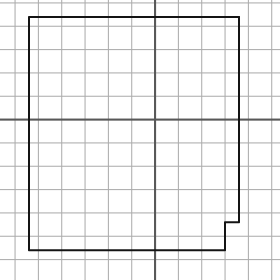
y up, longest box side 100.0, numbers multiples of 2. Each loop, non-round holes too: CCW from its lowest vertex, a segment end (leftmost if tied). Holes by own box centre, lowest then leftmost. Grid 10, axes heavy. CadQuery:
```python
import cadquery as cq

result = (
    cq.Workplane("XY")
    .moveTo(-54.0, -56.0)
    .lineTo(30.0, -56.0)
    .lineTo(30.0, -44.0)
    .lineTo(36.0, -44.0)
    .lineTo(36.0, 44.0)
    .lineTo(-54.0, 44.0)
    .close()
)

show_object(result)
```